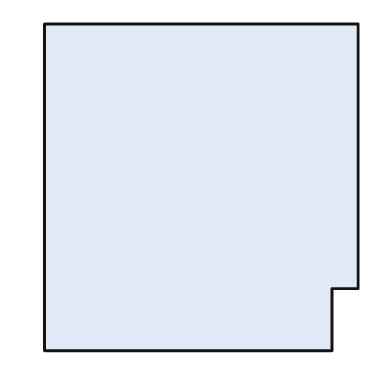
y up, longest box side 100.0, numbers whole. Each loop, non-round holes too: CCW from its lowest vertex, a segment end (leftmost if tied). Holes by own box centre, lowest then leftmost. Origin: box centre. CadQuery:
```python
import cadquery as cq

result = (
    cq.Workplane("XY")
    .moveTo(-48.0, -50.0)
    .lineTo(40.0, -50.0)
    .lineTo(40.0, -31.0)
    .lineTo(48.0, -31.0)
    .lineTo(48.0, 50.0)
    .lineTo(-48.0, 50.0)
    .close()
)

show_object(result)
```